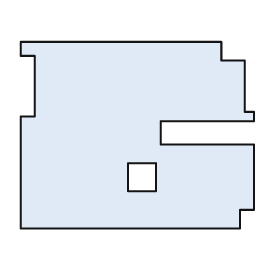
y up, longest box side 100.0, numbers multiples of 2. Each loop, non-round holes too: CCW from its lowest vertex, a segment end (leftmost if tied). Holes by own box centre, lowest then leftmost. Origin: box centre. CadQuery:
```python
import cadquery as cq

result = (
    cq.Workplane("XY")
    .moveTo(-50.0, -40.0)
    .lineTo(44.0, -40.0)
    .lineTo(44.0, -32.0)
    .lineTo(50.0, -32.0)
    .lineTo(50.0, -4.0)
    .lineTo(10.0, -4.0)
    .lineTo(10.0, 6.0)
    .lineTo(50.0, 6.0)
    .lineTo(50.0, 10.0)
    .lineTo(46.0, 10.0)
    .lineTo(46.0, 32.0)
    .lineTo(36.0, 32.0)
    .lineTo(36.0, 40.0)
    .lineTo(-50.0, 40.0)
    .lineTo(-50.0, 34.0)
    .lineTo(-44.0, 34.0)
    .lineTo(-44.0, 8.0)
    .lineTo(-50.0, 8.0)
    .close()
    .moveTo(-4.0, -24.0)
    .lineTo(8.0, -24.0)
    .lineTo(8.0, -12.0)
    .lineTo(-4.0, -12.0)
    .close()
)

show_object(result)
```